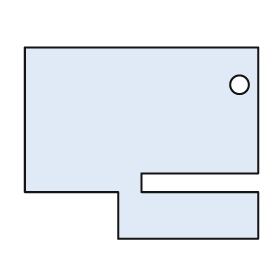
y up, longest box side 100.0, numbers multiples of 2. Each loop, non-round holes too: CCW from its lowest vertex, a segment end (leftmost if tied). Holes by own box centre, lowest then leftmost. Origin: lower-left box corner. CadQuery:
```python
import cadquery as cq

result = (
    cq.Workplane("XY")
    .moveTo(40.0, 0.0)
    .lineTo(100.0, 0.0)
    .lineTo(100.0, 20.0)
    .lineTo(50.0, 20.0)
    .lineTo(50.0, 28.0)
    .lineTo(100.0, 28.0)
    .lineTo(100.0, 82.0)
    .lineTo(0.0, 82.0)
    .lineTo(0.0, 20.0)
    .lineTo(40.0, 20.0)
    .close()
    .moveTo(92.0, 66.0)
    .circle(4.0)
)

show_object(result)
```